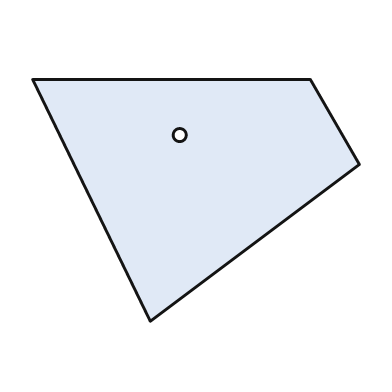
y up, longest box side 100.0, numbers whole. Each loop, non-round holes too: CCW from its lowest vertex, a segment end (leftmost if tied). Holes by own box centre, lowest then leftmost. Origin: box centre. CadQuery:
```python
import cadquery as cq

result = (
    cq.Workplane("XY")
    .moveTo(-14.0, -37.0)
    .lineTo(50.0, 11.0)
    .lineTo(35.0, 37.0)
    .lineTo(-50.0, 37.0)
    .close()
    .moveTo(-5.0, 20.0)
    .circle(2.0)
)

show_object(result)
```